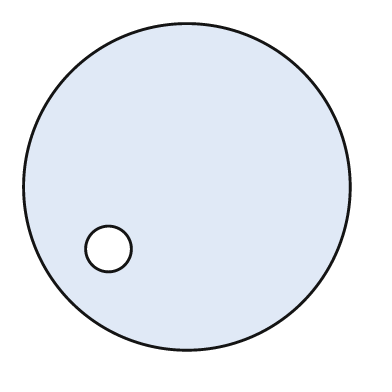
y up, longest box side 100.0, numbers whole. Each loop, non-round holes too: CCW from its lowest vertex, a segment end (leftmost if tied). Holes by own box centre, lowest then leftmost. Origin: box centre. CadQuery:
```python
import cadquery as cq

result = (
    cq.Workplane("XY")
    .moveTo(0.0, 0.0)
    .circle(50.0)
    .moveTo(-24.0, -19.0)
    .circle(7.0)
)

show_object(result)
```